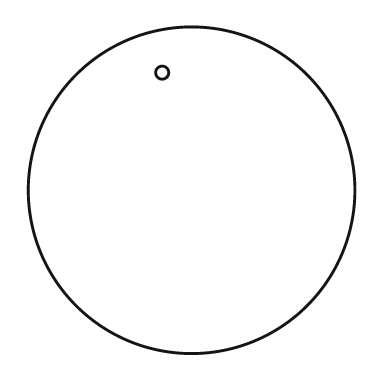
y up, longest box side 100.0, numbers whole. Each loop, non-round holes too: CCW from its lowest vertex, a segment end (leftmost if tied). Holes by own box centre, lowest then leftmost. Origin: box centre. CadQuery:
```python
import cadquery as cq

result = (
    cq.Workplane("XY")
    .moveTo(0.0, 0.0)
    .circle(50.0)
    .moveTo(-9.0, 36.0)
    .circle(2.0)
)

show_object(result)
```